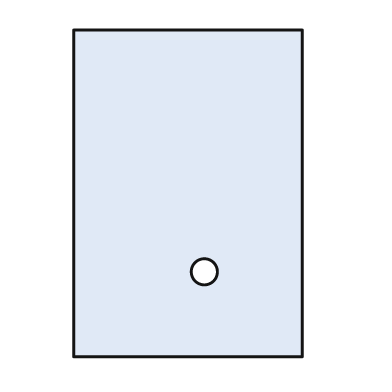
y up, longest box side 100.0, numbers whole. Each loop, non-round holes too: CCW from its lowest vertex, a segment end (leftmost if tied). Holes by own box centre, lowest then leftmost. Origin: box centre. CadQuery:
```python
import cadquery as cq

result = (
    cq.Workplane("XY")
    .moveTo(-35.0, -50.0)
    .lineTo(35.0, -50.0)
    .lineTo(35.0, 50.0)
    .lineTo(-35.0, 50.0)
    .close()
    .moveTo(5.0, -24.0)
    .circle(4.0)
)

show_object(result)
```